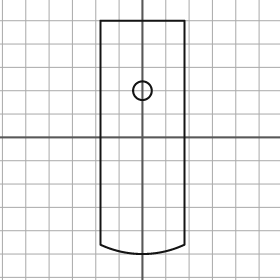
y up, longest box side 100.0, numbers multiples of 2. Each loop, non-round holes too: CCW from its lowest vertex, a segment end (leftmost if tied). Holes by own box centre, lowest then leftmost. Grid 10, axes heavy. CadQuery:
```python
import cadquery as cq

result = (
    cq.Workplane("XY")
    .moveTo(-18.0, -46.0)
    .threePointArc((0.0, -50.0), (18.0, -46.0))
    .lineTo(18.0, 50.0)
    .lineTo(-18.0, 50.0)
    .close()
    .moveTo(0.0, 20.0)
    .circle(4.0)
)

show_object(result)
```